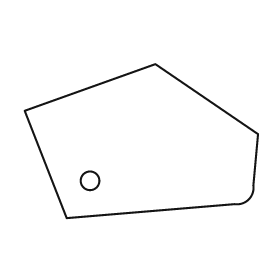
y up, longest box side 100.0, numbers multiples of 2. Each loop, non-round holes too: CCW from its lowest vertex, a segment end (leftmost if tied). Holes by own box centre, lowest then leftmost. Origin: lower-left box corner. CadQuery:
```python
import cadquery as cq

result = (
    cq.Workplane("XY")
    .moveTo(18.0, 0.0)
    .lineTo(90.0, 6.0)
    .threePointArc((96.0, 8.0), (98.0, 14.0))
    .lineTo(100.0, 36.0)
    .lineTo(56.0, 66.0)
    .lineTo(0.0, 46.0)
    .close()
    .moveTo(28.0, 16.0)
    .circle(4.0)
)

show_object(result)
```